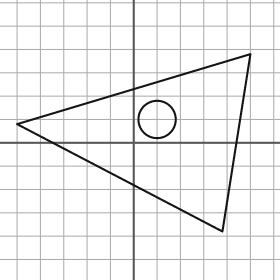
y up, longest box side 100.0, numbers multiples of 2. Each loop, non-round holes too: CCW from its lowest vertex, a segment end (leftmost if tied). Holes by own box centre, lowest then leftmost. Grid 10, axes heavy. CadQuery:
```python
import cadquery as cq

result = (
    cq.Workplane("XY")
    .moveTo(38.0, -38.0)
    .lineTo(50.0, 38.0)
    .lineTo(-50.0, 8.0)
    .close()
    .moveTo(10.0, 10.0)
    .circle(8.0)
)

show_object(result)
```